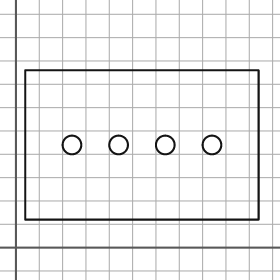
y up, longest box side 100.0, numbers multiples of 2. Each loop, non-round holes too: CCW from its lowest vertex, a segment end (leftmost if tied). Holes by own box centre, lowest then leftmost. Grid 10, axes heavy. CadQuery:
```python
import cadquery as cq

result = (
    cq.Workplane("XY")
    .moveTo(4.0, 12.0)
    .lineTo(104.0, 12.0)
    .lineTo(104.0, 76.0)
    .lineTo(4.0, 76.0)
    .close()
    .moveTo(24.0, 44.0)
    .circle(4.0)
    .moveTo(44.0, 44.0)
    .circle(4.0)
    .moveTo(64.0, 44.0)
    .circle(4.0)
    .moveTo(84.0, 44.0)
    .circle(4.0)
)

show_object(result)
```